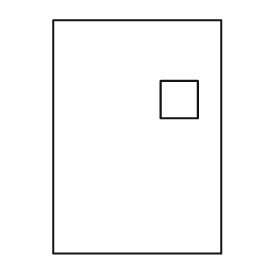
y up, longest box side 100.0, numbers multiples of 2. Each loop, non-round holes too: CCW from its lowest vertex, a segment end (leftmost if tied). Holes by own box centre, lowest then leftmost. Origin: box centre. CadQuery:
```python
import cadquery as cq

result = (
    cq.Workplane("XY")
    .moveTo(-36.0, -50.0)
    .lineTo(36.0, -50.0)
    .lineTo(36.0, 50.0)
    .lineTo(-36.0, 50.0)
    .close()
    .moveTo(10.0, 8.0)
    .lineTo(26.0, 8.0)
    .lineTo(26.0, 24.0)
    .lineTo(10.0, 24.0)
    .close()
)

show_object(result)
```